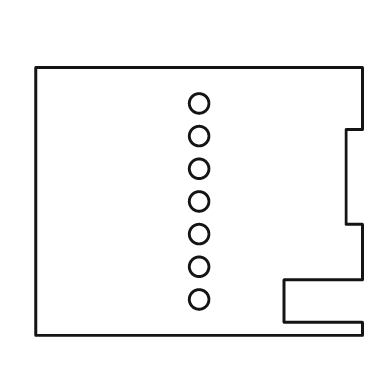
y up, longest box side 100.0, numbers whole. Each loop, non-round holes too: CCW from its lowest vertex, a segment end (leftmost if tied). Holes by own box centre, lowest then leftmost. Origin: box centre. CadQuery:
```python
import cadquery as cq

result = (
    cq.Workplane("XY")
    .moveTo(-50.0, -41.0)
    .lineTo(50.0, -41.0)
    .lineTo(50.0, -37.0)
    .lineTo(26.0, -37.0)
    .lineTo(26.0, -24.0)
    .lineTo(50.0, -24.0)
    .lineTo(50.0, -7.0)
    .lineTo(45.0, -7.0)
    .lineTo(45.0, 22.0)
    .lineTo(50.0, 22.0)
    .lineTo(50.0, 41.0)
    .lineTo(-50.0, 41.0)
    .close()
    .moveTo(0.0, -30.0)
    .circle(3.0)
    .moveTo(0.0, -20.0)
    .circle(3.0)
    .moveTo(0.0, -10.0)
    .circle(3.0)
    .moveTo(0.0, 0.0)
    .circle(3.0)
    .moveTo(0.0, 10.0)
    .circle(3.0)
    .moveTo(0.0, 20.0)
    .circle(3.0)
    .moveTo(0.0, 30.0)
    .circle(3.0)
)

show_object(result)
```